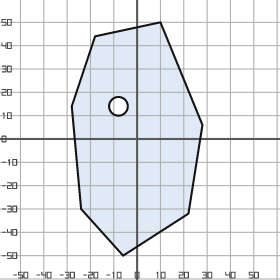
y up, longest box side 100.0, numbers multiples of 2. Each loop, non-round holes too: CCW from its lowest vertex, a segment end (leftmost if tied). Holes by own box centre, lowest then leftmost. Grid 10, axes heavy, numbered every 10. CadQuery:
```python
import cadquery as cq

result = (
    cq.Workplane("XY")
    .moveTo(-6.0, -50.0)
    .lineTo(22.0, -32.0)
    .lineTo(28.0, 6.0)
    .lineTo(10.0, 50.0)
    .lineTo(-18.0, 44.0)
    .lineTo(-28.0, 14.0)
    .lineTo(-24.0, -30.0)
    .close()
    .moveTo(-8.0, 14.0)
    .circle(4.0)
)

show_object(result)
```